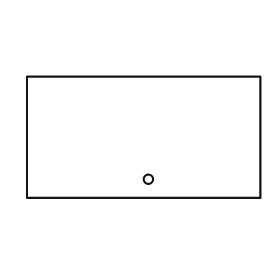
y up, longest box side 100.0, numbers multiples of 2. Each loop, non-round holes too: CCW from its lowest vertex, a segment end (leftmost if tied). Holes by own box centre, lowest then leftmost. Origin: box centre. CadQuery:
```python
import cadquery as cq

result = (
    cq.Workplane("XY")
    .moveTo(-50.0, -26.0)
    .lineTo(50.0, -26.0)
    .lineTo(50.0, 26.0)
    .lineTo(-50.0, 26.0)
    .close()
    .moveTo(2.0, -18.0)
    .circle(2.0)
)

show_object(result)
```